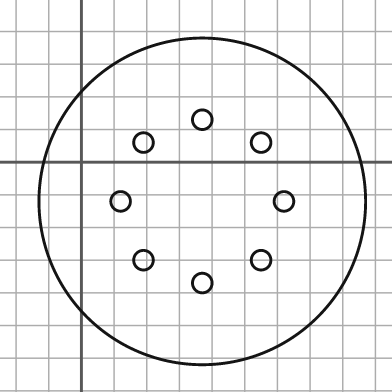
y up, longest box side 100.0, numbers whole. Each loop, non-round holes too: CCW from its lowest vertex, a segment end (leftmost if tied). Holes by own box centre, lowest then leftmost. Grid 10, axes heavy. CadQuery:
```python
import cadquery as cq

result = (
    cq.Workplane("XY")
    .moveTo(37.0, -12.0)
    .circle(50.0)
    .moveTo(37.0, -37.0)
    .circle(3.0)
    .moveTo(19.0, -30.0)
    .circle(3.0)
    .moveTo(55.0, -30.0)
    .circle(3.0)
    .moveTo(12.0, -12.0)
    .circle(3.0)
    .moveTo(62.0, -12.0)
    .circle(3.0)
    .moveTo(19.0, 6.0)
    .circle(3.0)
    .moveTo(55.0, 6.0)
    .circle(3.0)
    .moveTo(37.0, 13.0)
    .circle(3.0)
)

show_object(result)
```